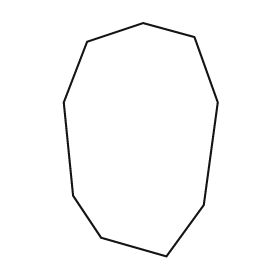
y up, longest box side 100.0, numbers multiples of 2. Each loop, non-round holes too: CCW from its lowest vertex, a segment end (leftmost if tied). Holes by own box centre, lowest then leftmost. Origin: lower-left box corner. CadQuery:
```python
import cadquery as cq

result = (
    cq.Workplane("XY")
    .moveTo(44.0, 0.0)
    .lineTo(60.0, 22.0)
    .lineTo(66.0, 66.0)
    .lineTo(56.0, 94.0)
    .lineTo(34.0, 100.0)
    .lineTo(10.0, 92.0)
    .lineTo(0.0, 66.0)
    .lineTo(4.0, 26.0)
    .lineTo(16.0, 8.0)
    .close()
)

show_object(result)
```